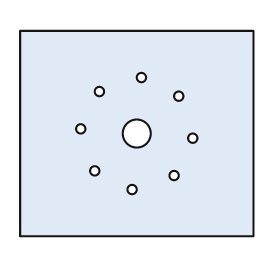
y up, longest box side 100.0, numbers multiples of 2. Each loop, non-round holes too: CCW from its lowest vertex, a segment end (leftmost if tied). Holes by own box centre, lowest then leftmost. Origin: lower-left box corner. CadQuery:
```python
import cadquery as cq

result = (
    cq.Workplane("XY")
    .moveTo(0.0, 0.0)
    .lineTo(100.0, 0.0)
    .lineTo(100.0, 88.0)
    .lineTo(0.0, 88.0)
    .close()
    .moveTo(48.0, 20.0)
    .circle(2.0)
    .moveTo(66.0, 26.0)
    .circle(2.0)
    .moveTo(32.0, 28.0)
    .circle(2.0)
    .moveTo(74.0, 42.0)
    .circle(2.0)
    .moveTo(50.0, 44.0)
    .circle(6.0)
    .moveTo(26.0, 46.0)
    .circle(2.0)
    .moveTo(68.0, 60.0)
    .circle(2.0)
    .moveTo(34.0, 62.0)
    .circle(2.0)
    .moveTo(52.0, 68.0)
    .circle(2.0)
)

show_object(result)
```